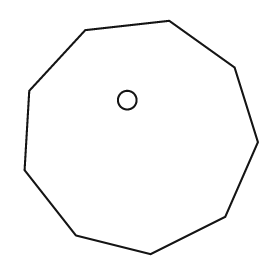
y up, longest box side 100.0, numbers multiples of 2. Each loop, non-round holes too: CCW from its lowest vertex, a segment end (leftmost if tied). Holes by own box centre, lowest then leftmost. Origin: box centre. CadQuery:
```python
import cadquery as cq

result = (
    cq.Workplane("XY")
    .moveTo(4.0, -50.0)
    .lineTo(36.0, -34.0)
    .lineTo(50.0, -2.0)
    .lineTo(40.0, 30.0)
    .lineTo(12.0, 50.0)
    .lineTo(-24.0, 46.0)
    .lineTo(-48.0, 20.0)
    .lineTo(-50.0, -14.0)
    .lineTo(-28.0, -42.0)
    .close()
    .moveTo(-6.0, 16.0)
    .circle(4.0)
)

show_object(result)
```